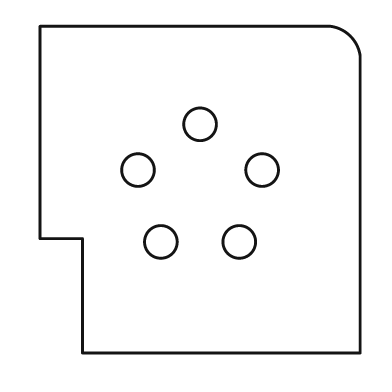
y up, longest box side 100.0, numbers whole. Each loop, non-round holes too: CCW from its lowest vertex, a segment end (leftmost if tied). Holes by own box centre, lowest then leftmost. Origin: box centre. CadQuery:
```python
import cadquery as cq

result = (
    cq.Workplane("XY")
    .moveTo(-36.0, -50.0)
    .lineTo(49.0, -50.0)
    .lineTo(49.0, 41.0)
    .threePointArc((46.0, 47.0), (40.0, 50.0))
    .lineTo(-49.0, 50.0)
    .lineTo(-49.0, -15.0)
    .lineTo(-36.0, -15.0)
    .close()
    .moveTo(-12.0, -16.0)
    .circle(5.0)
    .moveTo(12.0, -16.0)
    .circle(5.0)
    .moveTo(-19.0, 6.0)
    .circle(5.0)
    .moveTo(19.0, 6.0)
    .circle(5.0)
    .moveTo(0.0, 20.0)
    .circle(5.0)
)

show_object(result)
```